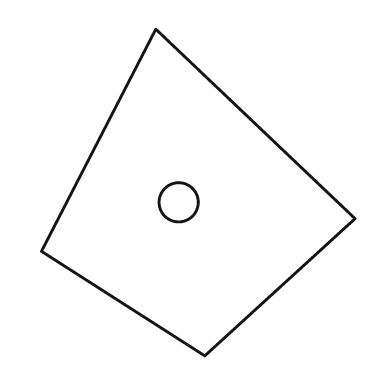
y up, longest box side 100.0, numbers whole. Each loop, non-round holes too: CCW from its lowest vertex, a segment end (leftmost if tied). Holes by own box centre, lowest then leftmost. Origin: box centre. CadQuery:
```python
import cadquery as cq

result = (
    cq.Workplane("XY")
    .moveTo(2.0, -50.0)
    .lineTo(48.0, -8.0)
    .lineTo(-13.0, 50.0)
    .lineTo(-48.0, -18.0)
    .close()
    .moveTo(-6.0, -3.0)
    .circle(6.0)
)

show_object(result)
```